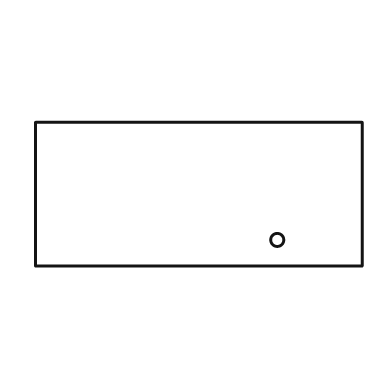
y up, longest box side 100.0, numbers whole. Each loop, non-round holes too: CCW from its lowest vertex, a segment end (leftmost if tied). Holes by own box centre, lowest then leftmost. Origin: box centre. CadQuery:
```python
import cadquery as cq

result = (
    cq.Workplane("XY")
    .moveTo(-50.0, -22.0)
    .lineTo(50.0, -22.0)
    .lineTo(50.0, 22.0)
    .lineTo(-50.0, 22.0)
    .close()
    .moveTo(24.0, -14.0)
    .circle(2.0)
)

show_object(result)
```